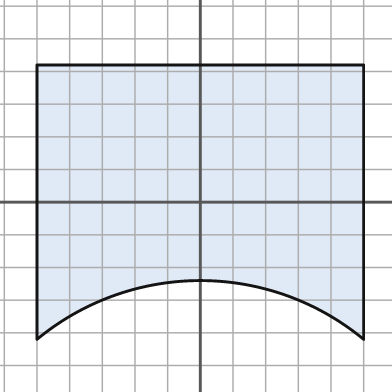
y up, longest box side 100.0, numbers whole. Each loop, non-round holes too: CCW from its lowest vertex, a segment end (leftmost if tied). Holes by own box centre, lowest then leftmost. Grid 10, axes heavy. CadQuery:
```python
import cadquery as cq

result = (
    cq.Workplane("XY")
    .moveTo(-50.0, -42.0)
    .threePointArc((0.0, -24.0), (50.0, -42.0))
    .lineTo(50.0, 42.0)
    .lineTo(-50.0, 42.0)
    .close()
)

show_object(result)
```